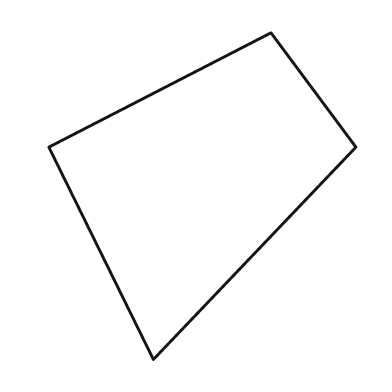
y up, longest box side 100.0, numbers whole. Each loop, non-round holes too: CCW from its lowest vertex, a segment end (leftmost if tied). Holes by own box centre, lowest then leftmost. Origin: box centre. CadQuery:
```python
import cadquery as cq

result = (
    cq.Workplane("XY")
    .moveTo(-15.0, -50.0)
    .lineTo(47.0, 15.0)
    .lineTo(21.0, 50.0)
    .lineTo(-47.0, 15.0)
    .close()
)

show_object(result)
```